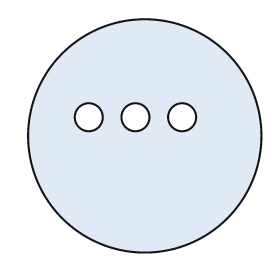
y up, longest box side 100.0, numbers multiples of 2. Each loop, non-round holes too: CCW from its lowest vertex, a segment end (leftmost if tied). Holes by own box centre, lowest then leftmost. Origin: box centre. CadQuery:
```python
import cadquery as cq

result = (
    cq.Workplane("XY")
    .moveTo(0.0, 0.0)
    .circle(50.0)
    .moveTo(-24.0, 8.0)
    .circle(6.0)
    .moveTo(-4.0, 8.0)
    .circle(6.0)
    .moveTo(16.0, 8.0)
    .circle(6.0)
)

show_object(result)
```